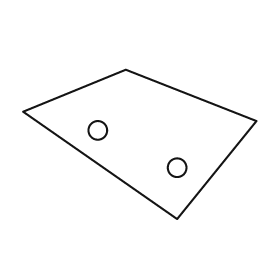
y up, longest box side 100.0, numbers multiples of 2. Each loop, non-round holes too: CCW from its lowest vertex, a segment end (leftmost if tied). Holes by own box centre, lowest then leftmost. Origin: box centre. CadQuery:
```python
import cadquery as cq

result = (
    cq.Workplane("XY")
    .moveTo(16.0, -32.0)
    .lineTo(50.0, 10.0)
    .lineTo(-6.0, 32.0)
    .lineTo(-50.0, 14.0)
    .close()
    .moveTo(16.0, -10.0)
    .circle(4.0)
    .moveTo(-18.0, 6.0)
    .circle(4.0)
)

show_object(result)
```